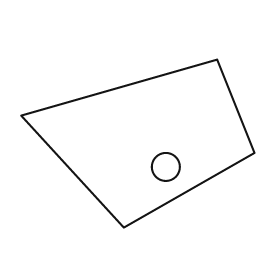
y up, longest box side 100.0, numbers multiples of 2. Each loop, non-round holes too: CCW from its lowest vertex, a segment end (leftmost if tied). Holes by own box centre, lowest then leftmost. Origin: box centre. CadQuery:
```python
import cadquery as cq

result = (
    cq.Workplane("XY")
    .moveTo(-6.0, -36.0)
    .lineTo(50.0, -4.0)
    .lineTo(34.0, 36.0)
    .lineTo(-50.0, 12.0)
    .close()
    .moveTo(12.0, -10.0)
    .circle(6.0)
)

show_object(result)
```